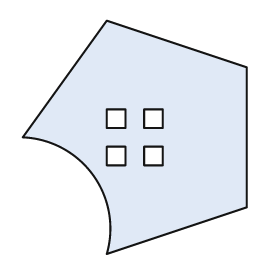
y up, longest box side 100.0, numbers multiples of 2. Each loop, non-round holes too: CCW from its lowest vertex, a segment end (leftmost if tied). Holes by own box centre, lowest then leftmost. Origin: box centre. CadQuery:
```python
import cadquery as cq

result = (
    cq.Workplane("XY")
    .moveTo(-12.0, -50.0)
    .lineTo(48.0, -30.0)
    .lineTo(48.0, 30.0)
    .lineTo(-12.0, 50.0)
    .lineTo(-48.0, 0.0)
    .threePointArc((-18.0, -16.0), (-12.0, -50.0))
    .close()
    .moveTo(-12.0, -12.0)
    .lineTo(-4.0, -12.0)
    .lineTo(-4.0, -4.0)
    .lineTo(-12.0, -4.0)
    .close()
    .moveTo(4.0, -12.0)
    .lineTo(12.0, -12.0)
    .lineTo(12.0, -4.0)
    .lineTo(4.0, -4.0)
    .close()
    .moveTo(-12.0, 4.0)
    .lineTo(-4.0, 4.0)
    .lineTo(-4.0, 12.0)
    .lineTo(-12.0, 12.0)
    .close()
    .moveTo(4.0, 4.0)
    .lineTo(12.0, 4.0)
    .lineTo(12.0, 12.0)
    .lineTo(4.0, 12.0)
    .close()
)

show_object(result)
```